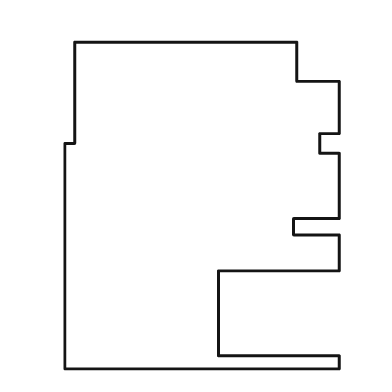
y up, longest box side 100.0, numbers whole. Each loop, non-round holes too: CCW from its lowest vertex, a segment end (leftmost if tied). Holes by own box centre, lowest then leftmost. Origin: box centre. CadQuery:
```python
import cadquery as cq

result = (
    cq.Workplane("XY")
    .moveTo(-42.0, -50.0)
    .lineTo(42.0, -50.0)
    .lineTo(42.0, -46.0)
    .lineTo(5.0, -46.0)
    .lineTo(5.0, -20.0)
    .lineTo(42.0, -20.0)
    .lineTo(42.0, -9.0)
    .lineTo(28.0, -9.0)
    .lineTo(28.0, -4.0)
    .lineTo(42.0, -4.0)
    .lineTo(42.0, 16.0)
    .lineTo(36.0, 16.0)
    .lineTo(36.0, 22.0)
    .lineTo(42.0, 22.0)
    .lineTo(42.0, 38.0)
    .lineTo(29.0, 38.0)
    .lineTo(29.0, 50.0)
    .lineTo(-39.0, 50.0)
    .lineTo(-39.0, 19.0)
    .lineTo(-42.0, 19.0)
    .close()
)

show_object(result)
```